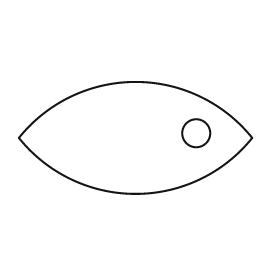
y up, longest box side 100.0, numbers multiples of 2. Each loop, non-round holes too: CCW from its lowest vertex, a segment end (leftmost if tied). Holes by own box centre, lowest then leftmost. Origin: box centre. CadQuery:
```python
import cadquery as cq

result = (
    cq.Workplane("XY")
    .moveTo(-50.0, 0.0)
    .threePointArc((0.0, -24.0), (50.0, 0.0))
    .threePointArc((0.0, 24.0), (-50.0, 0.0))
    .close()
    .moveTo(26.0, 2.0)
    .circle(6.0)
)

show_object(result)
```